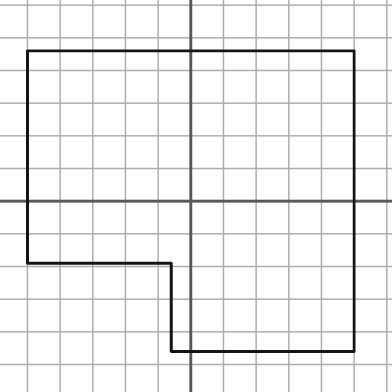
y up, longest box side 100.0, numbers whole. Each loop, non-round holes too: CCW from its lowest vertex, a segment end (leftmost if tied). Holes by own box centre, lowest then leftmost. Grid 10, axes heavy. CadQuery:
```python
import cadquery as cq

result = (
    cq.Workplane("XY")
    .moveTo(-6.0, -46.0)
    .lineTo(50.0, -46.0)
    .lineTo(50.0, 46.0)
    .lineTo(-50.0, 46.0)
    .lineTo(-50.0, -19.0)
    .lineTo(-6.0, -19.0)
    .close()
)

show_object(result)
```